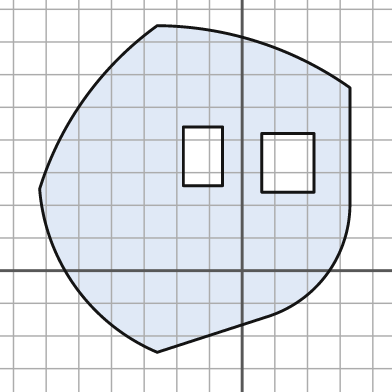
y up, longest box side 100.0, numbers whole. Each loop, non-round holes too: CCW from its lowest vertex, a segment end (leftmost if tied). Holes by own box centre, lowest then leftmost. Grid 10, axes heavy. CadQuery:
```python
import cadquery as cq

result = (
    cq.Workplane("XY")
    .moveTo(-26.0, -25.0)
    .lineTo(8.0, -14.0)
    .threePointArc((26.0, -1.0), (33.0, 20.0))
    .lineTo(33.0, 56.0)
    .threePointArc((5.0, 70.0), (-26.0, 75.0))
    .threePointArc((-48.0, 53.0), (-62.0, 25.0))
    .threePointArc((-51.0, -5.0), (-26.0, -25.0))
    .close()
    .moveTo(6.0, 24.0)
    .lineTo(22.0, 24.0)
    .lineTo(22.0, 42.0)
    .lineTo(6.0, 42.0)
    .close()
    .moveTo(-18.0, 26.0)
    .lineTo(-6.0, 26.0)
    .lineTo(-6.0, 44.0)
    .lineTo(-18.0, 44.0)
    .close()
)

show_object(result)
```